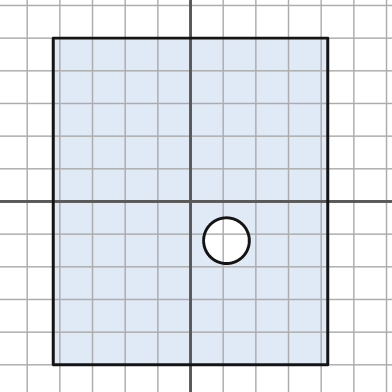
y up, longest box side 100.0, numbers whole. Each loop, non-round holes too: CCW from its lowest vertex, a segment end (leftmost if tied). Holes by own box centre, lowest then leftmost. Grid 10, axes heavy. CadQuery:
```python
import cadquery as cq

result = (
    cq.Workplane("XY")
    .moveTo(-42.0, -50.0)
    .lineTo(42.0, -50.0)
    .lineTo(42.0, 50.0)
    .lineTo(-42.0, 50.0)
    .close()
    .moveTo(11.0, -12.0)
    .circle(7.0)
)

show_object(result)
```